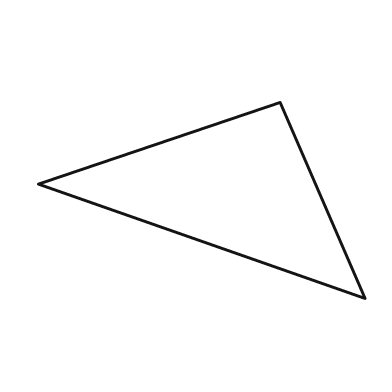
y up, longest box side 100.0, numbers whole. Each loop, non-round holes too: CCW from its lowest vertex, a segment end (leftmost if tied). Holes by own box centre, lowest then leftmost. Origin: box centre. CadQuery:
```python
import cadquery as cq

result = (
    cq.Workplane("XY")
    .moveTo(50.0, -30.0)
    .lineTo(24.0, 30.0)
    .lineTo(-50.0, 5.0)
    .close()
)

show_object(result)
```